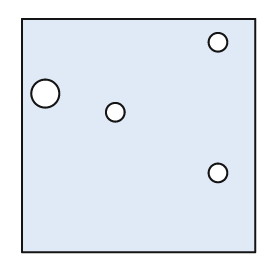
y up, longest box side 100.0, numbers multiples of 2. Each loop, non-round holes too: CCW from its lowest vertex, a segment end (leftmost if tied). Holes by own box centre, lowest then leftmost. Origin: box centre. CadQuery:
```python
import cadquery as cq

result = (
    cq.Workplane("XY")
    .moveTo(-50.0, -50.0)
    .lineTo(50.0, -50.0)
    .lineTo(50.0, 50.0)
    .lineTo(-50.0, 50.0)
    .close()
    .moveTo(34.0, -16.0)
    .circle(4.0)
    .moveTo(-10.0, 10.0)
    .circle(4.0)
    .moveTo(-40.0, 18.0)
    .circle(6.0)
    .moveTo(34.0, 40.0)
    .circle(4.0)
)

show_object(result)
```